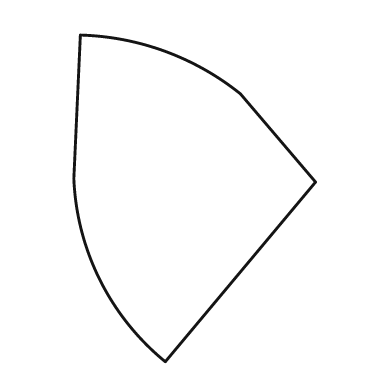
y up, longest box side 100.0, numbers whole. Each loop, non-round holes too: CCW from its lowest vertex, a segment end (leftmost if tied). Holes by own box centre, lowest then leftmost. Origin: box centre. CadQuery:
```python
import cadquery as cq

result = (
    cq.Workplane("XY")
    .moveTo(-9.0, -50.0)
    .lineTo(37.0, 5.0)
    .lineTo(14.0, 32.0)
    .threePointArc((-9.0, 45.0), (-35.0, 50.0))
    .lineTo(-37.0, 6.0)
    .threePointArc((-29.0, -25.0), (-9.0, -50.0))
    .close()
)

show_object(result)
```